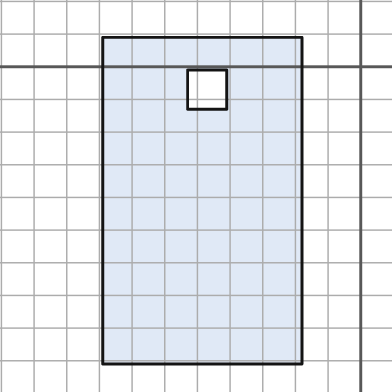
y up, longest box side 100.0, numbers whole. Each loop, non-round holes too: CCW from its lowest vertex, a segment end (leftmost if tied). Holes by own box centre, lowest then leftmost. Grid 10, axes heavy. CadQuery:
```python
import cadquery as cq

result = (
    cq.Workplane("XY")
    .moveTo(-79.0, -91.0)
    .lineTo(-18.0, -91.0)
    .lineTo(-18.0, 9.0)
    .lineTo(-79.0, 9.0)
    .close()
    .moveTo(-53.0, -13.0)
    .lineTo(-41.0, -13.0)
    .lineTo(-41.0, -1.0)
    .lineTo(-53.0, -1.0)
    .close()
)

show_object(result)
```